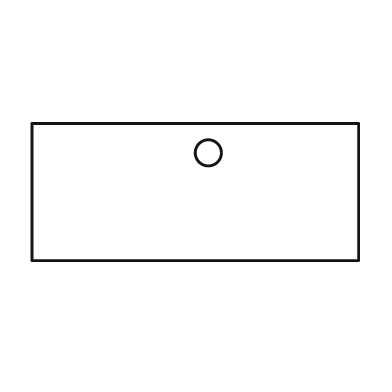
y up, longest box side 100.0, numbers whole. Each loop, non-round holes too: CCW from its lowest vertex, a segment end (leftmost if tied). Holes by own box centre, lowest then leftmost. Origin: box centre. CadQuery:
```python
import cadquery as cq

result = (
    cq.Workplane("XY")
    .moveTo(-50.0, -21.0)
    .lineTo(50.0, -21.0)
    .lineTo(50.0, 21.0)
    .lineTo(-50.0, 21.0)
    .close()
    .moveTo(4.0, 12.0)
    .circle(4.0)
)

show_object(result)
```